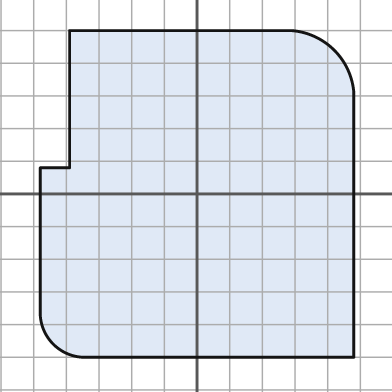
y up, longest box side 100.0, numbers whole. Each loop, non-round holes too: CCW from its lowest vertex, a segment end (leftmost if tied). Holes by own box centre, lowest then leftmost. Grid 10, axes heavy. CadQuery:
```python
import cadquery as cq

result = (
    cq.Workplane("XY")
    .moveTo(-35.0, -50.0)
    .lineTo(48.0, -50.0)
    .lineTo(48.0, 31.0)
    .threePointArc((42.0, 44.0), (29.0, 50.0))
    .lineTo(-39.0, 50.0)
    .lineTo(-39.0, 8.0)
    .lineTo(-48.0, 8.0)
    .lineTo(-48.0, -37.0)
    .threePointArc((-44.0, -46.0), (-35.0, -50.0))
    .close()
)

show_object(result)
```